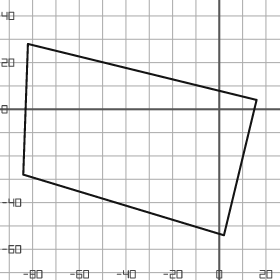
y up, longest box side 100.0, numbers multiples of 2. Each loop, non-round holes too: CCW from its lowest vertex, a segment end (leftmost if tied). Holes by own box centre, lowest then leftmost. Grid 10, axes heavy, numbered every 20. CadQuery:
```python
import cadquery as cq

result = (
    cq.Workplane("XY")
    .moveTo(2.0, -54.0)
    .lineTo(16.0, 4.0)
    .lineTo(-82.0, 28.0)
    .lineTo(-84.0, -28.0)
    .close()
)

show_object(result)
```